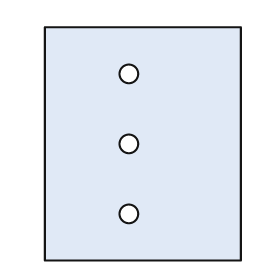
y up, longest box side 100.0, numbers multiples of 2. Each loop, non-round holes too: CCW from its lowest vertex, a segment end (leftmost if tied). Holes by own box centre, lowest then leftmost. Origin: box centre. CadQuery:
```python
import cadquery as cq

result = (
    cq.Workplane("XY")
    .moveTo(-42.0, -50.0)
    .lineTo(42.0, -50.0)
    .lineTo(42.0, 50.0)
    .lineTo(-42.0, 50.0)
    .close()
    .moveTo(-6.0, -30.0)
    .circle(4.0)
    .moveTo(-6.0, 0.0)
    .circle(4.0)
    .moveTo(-6.0, 30.0)
    .circle(4.0)
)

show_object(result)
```